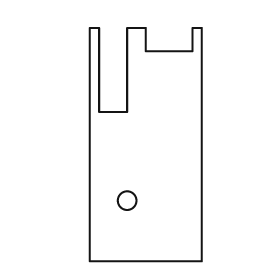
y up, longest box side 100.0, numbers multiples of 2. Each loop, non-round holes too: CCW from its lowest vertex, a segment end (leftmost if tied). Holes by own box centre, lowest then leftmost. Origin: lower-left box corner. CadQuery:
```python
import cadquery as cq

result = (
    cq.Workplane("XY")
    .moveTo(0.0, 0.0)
    .lineTo(48.0, 0.0)
    .lineTo(48.0, 100.0)
    .lineTo(44.0, 100.0)
    .lineTo(44.0, 90.0)
    .lineTo(24.0, 90.0)
    .lineTo(24.0, 100.0)
    .lineTo(16.0, 100.0)
    .lineTo(16.0, 64.0)
    .lineTo(4.0, 64.0)
    .lineTo(4.0, 100.0)
    .lineTo(0.0, 100.0)
    .close()
    .moveTo(16.0, 26.0)
    .circle(4.0)
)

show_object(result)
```